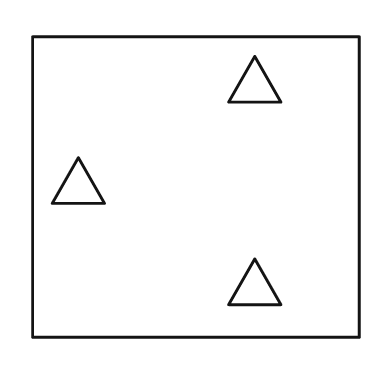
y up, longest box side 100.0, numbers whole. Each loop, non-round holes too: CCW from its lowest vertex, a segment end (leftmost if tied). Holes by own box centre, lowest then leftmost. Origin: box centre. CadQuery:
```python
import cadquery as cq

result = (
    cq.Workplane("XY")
    .moveTo(-50.0, -46.0)
    .lineTo(50.0, -46.0)
    .lineTo(50.0, 46.0)
    .lineTo(-50.0, 46.0)
    .close()
    .moveTo(10.0, -36.0)
    .lineTo(26.0, -36.0)
    .lineTo(18.0, -22.0)
    .close()
    .moveTo(-44.0, -5.0)
    .lineTo(-28.0, -5.0)
    .lineTo(-36.0, 9.0)
    .close()
    .moveTo(10.0, 26.0)
    .lineTo(26.0, 26.0)
    .lineTo(18.0, 40.0)
    .close()
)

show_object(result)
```